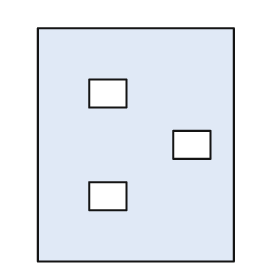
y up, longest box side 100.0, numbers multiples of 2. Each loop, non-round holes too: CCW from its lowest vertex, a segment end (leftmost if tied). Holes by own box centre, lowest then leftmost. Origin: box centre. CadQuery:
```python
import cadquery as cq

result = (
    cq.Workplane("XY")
    .moveTo(-42.0, -50.0)
    .lineTo(42.0, -50.0)
    .lineTo(42.0, 50.0)
    .lineTo(-42.0, 50.0)
    .close()
    .moveTo(-20.0, -28.0)
    .lineTo(-4.0, -28.0)
    .lineTo(-4.0, -16.0)
    .lineTo(-20.0, -16.0)
    .close()
    .moveTo(16.0, -6.0)
    .lineTo(32.0, -6.0)
    .lineTo(32.0, 6.0)
    .lineTo(16.0, 6.0)
    .close()
    .moveTo(-20.0, 16.0)
    .lineTo(-4.0, 16.0)
    .lineTo(-4.0, 28.0)
    .lineTo(-20.0, 28.0)
    .close()
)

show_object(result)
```